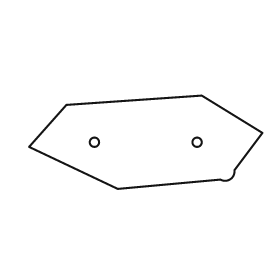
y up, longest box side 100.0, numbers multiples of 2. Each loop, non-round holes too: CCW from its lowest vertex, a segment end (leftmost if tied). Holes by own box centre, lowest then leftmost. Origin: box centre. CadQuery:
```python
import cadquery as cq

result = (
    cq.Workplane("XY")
    .moveTo(-12.0, -20.0)
    .lineTo(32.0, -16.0)
    .threePointArc((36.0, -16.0), (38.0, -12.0))
    .lineTo(50.0, 4.0)
    .lineTo(24.0, 20.0)
    .lineTo(-34.0, 16.0)
    .lineTo(-50.0, -2.0)
    .close()
    .moveTo(-22.0, 0.0)
    .circle(2.0)
    .moveTo(22.0, 0.0)
    .circle(2.0)
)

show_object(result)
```